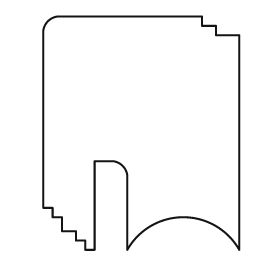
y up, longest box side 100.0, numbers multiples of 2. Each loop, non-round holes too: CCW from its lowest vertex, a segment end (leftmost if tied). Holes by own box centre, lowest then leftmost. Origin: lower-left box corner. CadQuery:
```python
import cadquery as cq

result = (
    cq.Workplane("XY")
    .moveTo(18.0, 0.0)
    .lineTo(22.0, 0.0)
    .lineTo(22.0, 38.0)
    .lineTo(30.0, 38.0)
    .threePointArc((34.0, 36.0), (36.0, 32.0))
    .lineTo(36.0, 0.0)
    .threePointArc((60.0, 14.0), (84.0, 0.0))
    .lineTo(84.0, 92.0)
    .lineTo(74.0, 92.0)
    .lineTo(74.0, 96.0)
    .lineTo(68.0, 96.0)
    .lineTo(68.0, 100.0)
    .lineTo(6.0, 100.0)
    .threePointArc((2.0, 98.0), (0.0, 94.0))
    .lineTo(0.0, 18.0)
    .lineTo(4.0, 18.0)
    .lineTo(4.0, 14.0)
    .lineTo(8.0, 14.0)
    .lineTo(8.0, 8.0)
    .lineTo(14.0, 8.0)
    .lineTo(14.0, 4.0)
    .lineTo(18.0, 4.0)
    .close()
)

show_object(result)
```